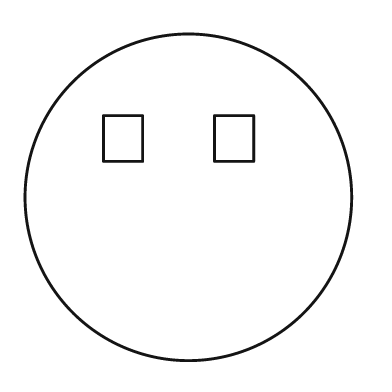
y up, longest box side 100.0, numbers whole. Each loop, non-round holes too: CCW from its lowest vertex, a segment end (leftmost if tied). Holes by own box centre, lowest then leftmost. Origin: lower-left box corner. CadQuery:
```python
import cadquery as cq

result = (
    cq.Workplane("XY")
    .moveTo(50.0, 50.0)
    .circle(50.0)
    .moveTo(24.0, 61.0)
    .lineTo(36.0, 61.0)
    .lineTo(36.0, 75.0)
    .lineTo(24.0, 75.0)
    .close()
    .moveTo(58.0, 61.0)
    .lineTo(70.0, 61.0)
    .lineTo(70.0, 75.0)
    .lineTo(58.0, 75.0)
    .close()
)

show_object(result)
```